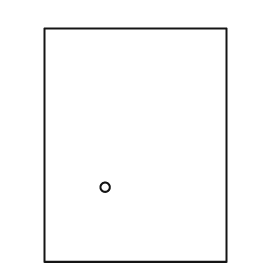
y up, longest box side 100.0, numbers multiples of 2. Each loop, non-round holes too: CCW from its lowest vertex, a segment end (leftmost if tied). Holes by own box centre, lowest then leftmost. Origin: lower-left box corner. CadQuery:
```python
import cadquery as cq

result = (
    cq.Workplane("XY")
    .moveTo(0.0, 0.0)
    .lineTo(78.0, 0.0)
    .lineTo(78.0, 100.0)
    .lineTo(0.0, 100.0)
    .close()
    .moveTo(26.0, 32.0)
    .circle(2.0)
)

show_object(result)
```